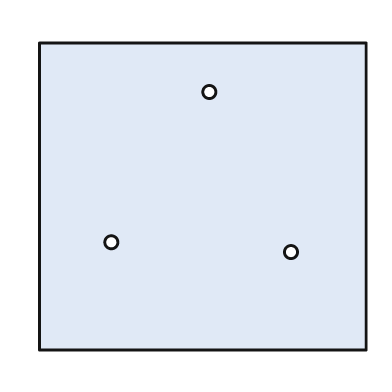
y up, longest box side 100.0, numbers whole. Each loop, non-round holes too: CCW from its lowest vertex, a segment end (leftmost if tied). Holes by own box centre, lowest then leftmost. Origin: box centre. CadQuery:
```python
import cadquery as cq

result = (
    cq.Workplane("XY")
    .moveTo(-50.0, -47.0)
    .lineTo(50.0, -47.0)
    .lineTo(50.0, 47.0)
    .lineTo(-50.0, 47.0)
    .close()
    .moveTo(27.0, -17.0)
    .circle(2.0)
    .moveTo(-28.0, -14.0)
    .circle(2.0)
    .moveTo(2.0, 32.0)
    .circle(2.0)
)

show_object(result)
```